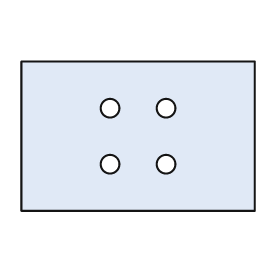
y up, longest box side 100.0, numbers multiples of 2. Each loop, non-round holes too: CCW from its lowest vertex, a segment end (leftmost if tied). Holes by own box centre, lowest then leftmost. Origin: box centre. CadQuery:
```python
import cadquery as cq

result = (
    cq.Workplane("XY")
    .moveTo(-50.0, -32.0)
    .lineTo(50.0, -32.0)
    .lineTo(50.0, 32.0)
    .lineTo(-50.0, 32.0)
    .close()
    .moveTo(-12.0, -12.0)
    .circle(4.0)
    .moveTo(12.0, -12.0)
    .circle(4.0)
    .moveTo(-12.0, 12.0)
    .circle(4.0)
    .moveTo(12.0, 12.0)
    .circle(4.0)
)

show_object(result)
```